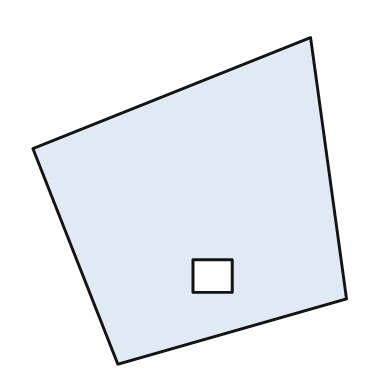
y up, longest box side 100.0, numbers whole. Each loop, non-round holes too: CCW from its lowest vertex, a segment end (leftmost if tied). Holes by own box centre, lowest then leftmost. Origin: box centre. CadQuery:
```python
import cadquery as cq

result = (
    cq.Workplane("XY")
    .moveTo(-22.0, -50.0)
    .lineTo(48.0, -30.0)
    .lineTo(37.0, 50.0)
    .lineTo(-48.0, 16.0)
    .close()
    .moveTo(1.0, -28.0)
    .lineTo(13.0, -28.0)
    .lineTo(13.0, -18.0)
    .lineTo(1.0, -18.0)
    .close()
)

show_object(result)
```